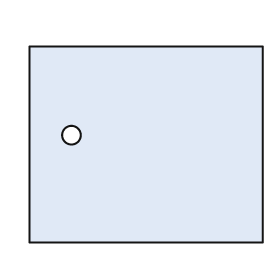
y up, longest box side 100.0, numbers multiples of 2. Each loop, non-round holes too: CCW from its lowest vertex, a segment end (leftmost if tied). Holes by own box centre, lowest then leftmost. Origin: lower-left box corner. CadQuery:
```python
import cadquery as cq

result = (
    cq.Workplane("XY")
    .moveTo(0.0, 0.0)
    .lineTo(100.0, 0.0)
    .lineTo(100.0, 84.0)
    .lineTo(0.0, 84.0)
    .close()
    .moveTo(18.0, 46.0)
    .circle(4.0)
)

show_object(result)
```